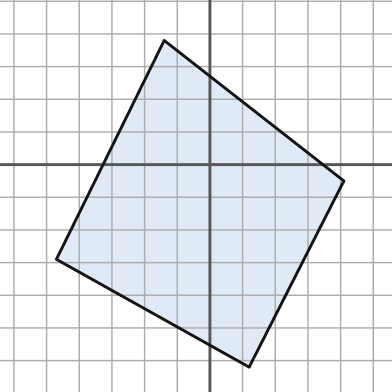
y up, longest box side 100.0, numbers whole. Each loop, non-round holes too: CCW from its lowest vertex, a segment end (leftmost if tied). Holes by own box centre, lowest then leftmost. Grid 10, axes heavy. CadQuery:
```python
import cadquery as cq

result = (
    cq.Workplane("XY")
    .moveTo(12.0, -62.0)
    .lineTo(41.0, -5.0)
    .lineTo(-14.0, 38.0)
    .lineTo(-47.0, -29.0)
    .close()
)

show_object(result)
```